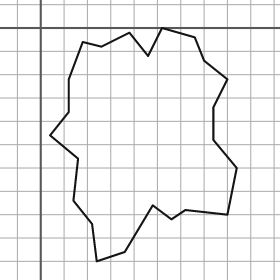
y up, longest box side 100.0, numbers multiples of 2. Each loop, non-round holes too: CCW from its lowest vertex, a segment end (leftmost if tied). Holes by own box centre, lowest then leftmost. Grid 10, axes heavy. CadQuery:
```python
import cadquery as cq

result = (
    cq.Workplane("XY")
    .moveTo(24.0, -100.0)
    .lineTo(36.0, -96.0)
    .lineTo(48.0, -76.0)
    .lineTo(56.0, -82.0)
    .lineTo(62.0, -78.0)
    .lineTo(80.0, -80.0)
    .lineTo(84.0, -60.0)
    .lineTo(74.0, -48.0)
    .lineTo(74.0, -34.0)
    .lineTo(80.0, -22.0)
    .lineTo(70.0, -14.0)
    .lineTo(66.0, -4.0)
    .lineTo(52.0, 0.0)
    .lineTo(46.0, -12.0)
    .lineTo(38.0, -2.0)
    .lineTo(26.0, -8.0)
    .lineTo(18.0, -6.0)
    .lineTo(12.0, -22.0)
    .lineTo(12.0, -36.0)
    .lineTo(4.0, -46.0)
    .lineTo(16.0, -56.0)
    .lineTo(14.0, -74.0)
    .lineTo(22.0, -84.0)
    .close()
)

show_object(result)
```